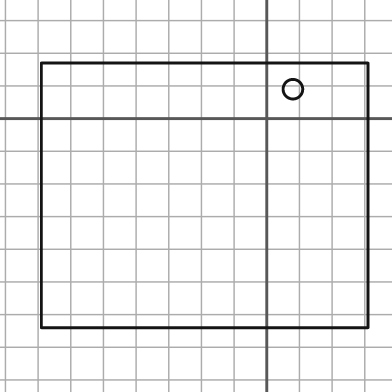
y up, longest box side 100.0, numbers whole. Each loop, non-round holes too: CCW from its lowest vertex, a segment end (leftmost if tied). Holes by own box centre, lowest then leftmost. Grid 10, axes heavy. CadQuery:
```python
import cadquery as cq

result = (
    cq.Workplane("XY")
    .moveTo(-69.0, -64.0)
    .lineTo(31.0, -64.0)
    .lineTo(31.0, 17.0)
    .lineTo(-69.0, 17.0)
    .close()
    .moveTo(8.0, 9.0)
    .circle(3.0)
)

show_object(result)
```